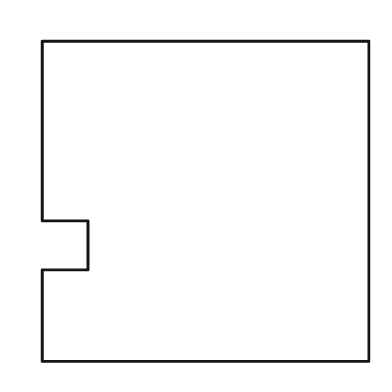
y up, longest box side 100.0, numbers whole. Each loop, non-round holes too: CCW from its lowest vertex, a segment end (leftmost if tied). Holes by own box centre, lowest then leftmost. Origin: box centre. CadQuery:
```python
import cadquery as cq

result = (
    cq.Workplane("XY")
    .moveTo(-50.0, -49.0)
    .lineTo(50.0, -49.0)
    .lineTo(50.0, 49.0)
    .lineTo(-50.0, 49.0)
    .lineTo(-50.0, -6.0)
    .lineTo(-36.0, -6.0)
    .lineTo(-36.0, -21.0)
    .lineTo(-50.0, -21.0)
    .close()
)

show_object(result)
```